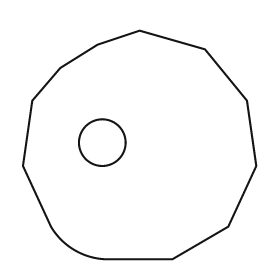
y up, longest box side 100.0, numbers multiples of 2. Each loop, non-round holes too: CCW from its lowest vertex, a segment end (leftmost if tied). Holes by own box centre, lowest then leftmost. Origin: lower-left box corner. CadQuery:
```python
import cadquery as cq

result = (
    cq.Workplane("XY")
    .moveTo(36.0, 0.0)
    .lineTo(64.0, 0.0)
    .lineTo(88.0, 14.0)
    .lineTo(100.0, 40.0)
    .lineTo(96.0, 68.0)
    .lineTo(78.0, 90.0)
    .lineTo(50.0, 98.0)
    .lineTo(32.0, 92.0)
    .lineTo(16.0, 82.0)
    .lineTo(4.0, 68.0)
    .lineTo(0.0, 40.0)
    .lineTo(12.0, 14.0)
    .threePointArc((22.0, 4.0), (36.0, 0.0))
    .close()
    .moveTo(34.0, 50.0)
    .circle(10.0)
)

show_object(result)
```